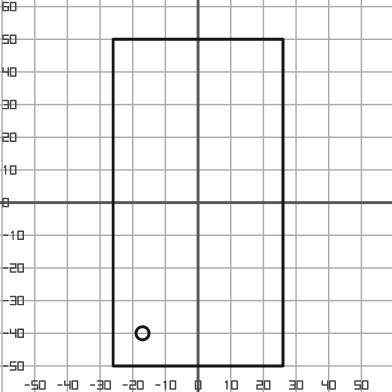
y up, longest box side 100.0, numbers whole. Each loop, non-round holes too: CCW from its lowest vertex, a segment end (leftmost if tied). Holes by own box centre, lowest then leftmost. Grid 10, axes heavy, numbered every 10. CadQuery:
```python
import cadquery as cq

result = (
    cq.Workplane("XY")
    .moveTo(-26.0, -50.0)
    .lineTo(26.0, -50.0)
    .lineTo(26.0, 50.0)
    .lineTo(-26.0, 50.0)
    .close()
    .moveTo(-17.0, -40.0)
    .circle(2.0)
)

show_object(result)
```